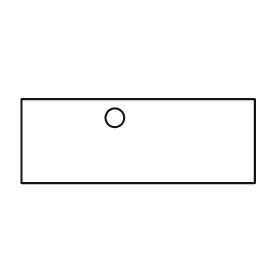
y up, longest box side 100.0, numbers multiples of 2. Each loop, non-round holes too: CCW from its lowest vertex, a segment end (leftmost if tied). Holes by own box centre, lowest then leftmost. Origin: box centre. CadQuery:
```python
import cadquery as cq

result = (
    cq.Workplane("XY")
    .moveTo(-50.0, -18.0)
    .lineTo(50.0, -18.0)
    .lineTo(50.0, 18.0)
    .lineTo(-50.0, 18.0)
    .close()
    .moveTo(-10.0, 10.0)
    .circle(4.0)
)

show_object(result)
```